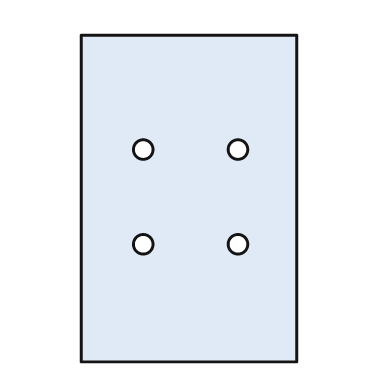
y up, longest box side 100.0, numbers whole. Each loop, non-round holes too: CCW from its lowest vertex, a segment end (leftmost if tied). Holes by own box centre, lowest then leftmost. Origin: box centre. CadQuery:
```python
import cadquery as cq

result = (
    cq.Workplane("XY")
    .moveTo(-33.0, -50.0)
    .lineTo(33.0, -50.0)
    .lineTo(33.0, 50.0)
    .lineTo(-33.0, 50.0)
    .close()
    .moveTo(-14.0, -14.0)
    .circle(3.0)
    .moveTo(15.0, -14.0)
    .circle(3.0)
    .moveTo(-14.0, 15.0)
    .circle(3.0)
    .moveTo(15.0, 15.0)
    .circle(3.0)
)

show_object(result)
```